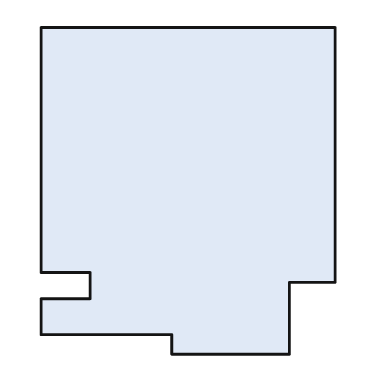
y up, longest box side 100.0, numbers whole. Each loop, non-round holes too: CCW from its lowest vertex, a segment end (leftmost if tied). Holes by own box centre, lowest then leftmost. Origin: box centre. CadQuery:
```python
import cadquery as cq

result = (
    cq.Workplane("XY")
    .moveTo(-5.0, -50.0)
    .lineTo(31.0, -50.0)
    .lineTo(31.0, -28.0)
    .lineTo(45.0, -28.0)
    .lineTo(45.0, 50.0)
    .lineTo(-45.0, 50.0)
    .lineTo(-45.0, -25.0)
    .lineTo(-30.0, -25.0)
    .lineTo(-30.0, -33.0)
    .lineTo(-45.0, -33.0)
    .lineTo(-45.0, -44.0)
    .lineTo(-5.0, -44.0)
    .close()
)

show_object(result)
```